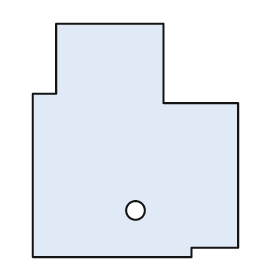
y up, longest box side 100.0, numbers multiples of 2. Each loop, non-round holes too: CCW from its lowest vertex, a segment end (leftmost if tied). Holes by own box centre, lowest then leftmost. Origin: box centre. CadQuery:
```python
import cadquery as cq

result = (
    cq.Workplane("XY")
    .moveTo(-44.0, -50.0)
    .lineTo(24.0, -50.0)
    .lineTo(24.0, -46.0)
    .lineTo(44.0, -46.0)
    .lineTo(44.0, 16.0)
    .lineTo(12.0, 16.0)
    .lineTo(12.0, 50.0)
    .lineTo(-34.0, 50.0)
    .lineTo(-34.0, 20.0)
    .lineTo(-44.0, 20.0)
    .close()
    .moveTo(0.0, -30.0)
    .circle(4.0)
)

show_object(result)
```